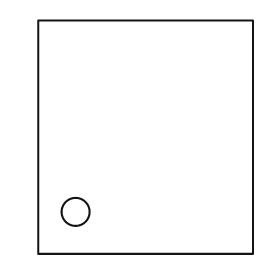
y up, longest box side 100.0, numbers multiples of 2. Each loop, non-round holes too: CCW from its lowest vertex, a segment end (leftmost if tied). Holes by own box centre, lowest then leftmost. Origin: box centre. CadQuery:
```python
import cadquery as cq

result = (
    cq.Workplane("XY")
    .moveTo(-46.0, -50.0)
    .lineTo(46.0, -50.0)
    .lineTo(46.0, 50.0)
    .lineTo(-46.0, 50.0)
    .close()
    .moveTo(-30.0, -32.0)
    .circle(6.0)
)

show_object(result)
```